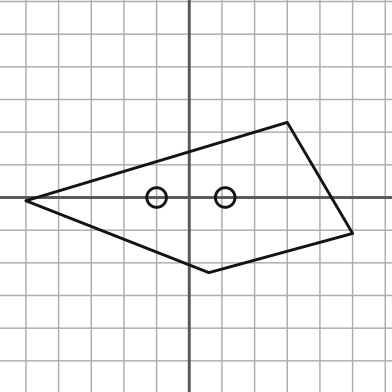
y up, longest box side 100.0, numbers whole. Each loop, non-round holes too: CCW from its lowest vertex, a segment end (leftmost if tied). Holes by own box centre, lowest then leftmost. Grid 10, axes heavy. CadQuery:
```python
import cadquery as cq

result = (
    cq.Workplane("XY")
    .moveTo(6.0, -23.0)
    .lineTo(50.0, -11.0)
    .lineTo(30.0, 23.0)
    .lineTo(-50.0, -1.0)
    .close()
    .moveTo(-10.0, 0.0)
    .circle(3.0)
    .moveTo(11.0, 0.0)
    .circle(3.0)
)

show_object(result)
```